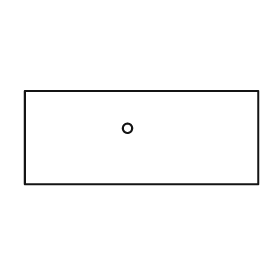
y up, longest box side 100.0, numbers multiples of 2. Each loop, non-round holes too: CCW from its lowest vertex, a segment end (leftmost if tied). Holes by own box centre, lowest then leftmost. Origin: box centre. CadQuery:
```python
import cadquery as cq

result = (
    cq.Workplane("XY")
    .moveTo(-50.0, -20.0)
    .lineTo(50.0, -20.0)
    .lineTo(50.0, 20.0)
    .lineTo(-50.0, 20.0)
    .close()
    .moveTo(-6.0, 4.0)
    .circle(2.0)
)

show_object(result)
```